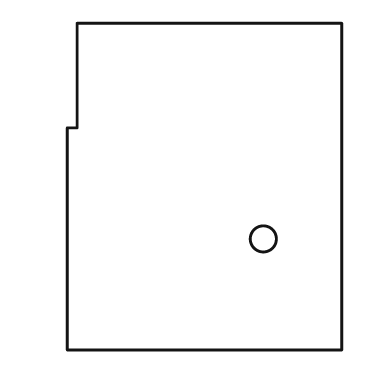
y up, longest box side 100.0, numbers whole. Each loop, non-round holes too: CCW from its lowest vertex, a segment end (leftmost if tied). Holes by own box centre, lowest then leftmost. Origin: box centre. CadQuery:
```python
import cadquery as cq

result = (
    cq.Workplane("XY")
    .moveTo(-42.0, -50.0)
    .lineTo(42.0, -50.0)
    .lineTo(42.0, 50.0)
    .lineTo(-39.0, 50.0)
    .lineTo(-39.0, 18.0)
    .lineTo(-42.0, 18.0)
    .close()
    .moveTo(18.0, -16.0)
    .circle(4.0)
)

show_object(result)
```